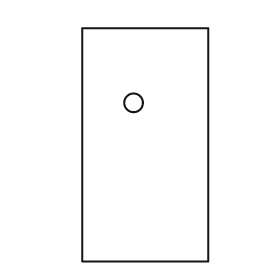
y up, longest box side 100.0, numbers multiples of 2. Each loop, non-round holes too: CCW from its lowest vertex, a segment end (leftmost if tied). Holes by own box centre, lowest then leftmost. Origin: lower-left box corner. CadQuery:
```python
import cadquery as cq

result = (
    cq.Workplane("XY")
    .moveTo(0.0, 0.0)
    .lineTo(54.0, 0.0)
    .lineTo(54.0, 100.0)
    .lineTo(0.0, 100.0)
    .close()
    .moveTo(22.0, 68.0)
    .circle(4.0)
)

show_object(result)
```